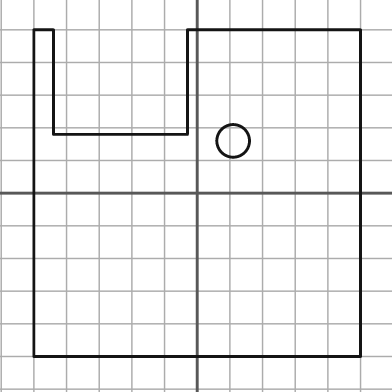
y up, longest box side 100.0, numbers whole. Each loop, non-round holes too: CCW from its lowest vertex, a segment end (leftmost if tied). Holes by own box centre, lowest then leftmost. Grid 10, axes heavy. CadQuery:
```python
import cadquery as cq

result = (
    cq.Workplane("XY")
    .moveTo(-50.0, -50.0)
    .lineTo(50.0, -50.0)
    .lineTo(50.0, 50.0)
    .lineTo(-3.0, 50.0)
    .lineTo(-3.0, 18.0)
    .lineTo(-44.0, 18.0)
    .lineTo(-44.0, 50.0)
    .lineTo(-50.0, 50.0)
    .close()
    .moveTo(11.0, 16.0)
    .circle(5.0)
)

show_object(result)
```